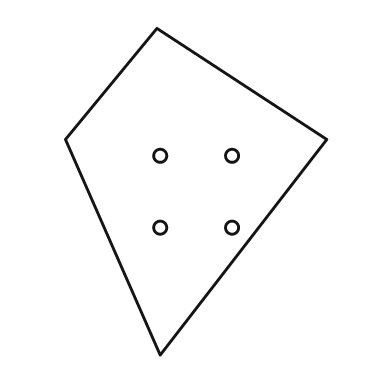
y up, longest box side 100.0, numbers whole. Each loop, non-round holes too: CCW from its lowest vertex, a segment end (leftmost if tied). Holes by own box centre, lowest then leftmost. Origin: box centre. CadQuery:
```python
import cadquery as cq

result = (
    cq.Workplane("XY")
    .moveTo(-11.0, -50.0)
    .lineTo(40.0, 16.0)
    .lineTo(-12.0, 50.0)
    .lineTo(-40.0, 16.0)
    .close()
    .moveTo(-11.0, -11.0)
    .circle(2.0)
    .moveTo(11.0, -11.0)
    .circle(2.0)
    .moveTo(-11.0, 11.0)
    .circle(2.0)
    .moveTo(11.0, 11.0)
    .circle(2.0)
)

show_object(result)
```